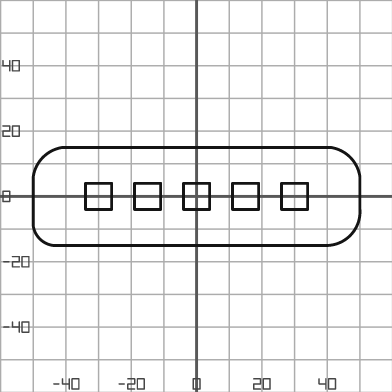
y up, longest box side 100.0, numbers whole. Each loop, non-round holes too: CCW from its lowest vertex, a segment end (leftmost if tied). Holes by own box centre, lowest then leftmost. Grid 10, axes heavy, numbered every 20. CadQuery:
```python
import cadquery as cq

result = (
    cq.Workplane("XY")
    .moveTo(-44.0, -15.0)
    .lineTo(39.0, -15.0)
    .threePointArc((47.0, -12.0), (50.0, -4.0))
    .lineTo(50.0, 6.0)
    .threePointArc((47.0, 12.0), (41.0, 15.0))
    .lineTo(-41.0, 15.0)
    .threePointArc((-47.0, 12.0), (-50.0, 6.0))
    .lineTo(-50.0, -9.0)
    .threePointArc((-48.0, -13.0), (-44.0, -15.0))
    .close()
    .moveTo(-34.0, -4.0)
    .lineTo(-26.0, -4.0)
    .lineTo(-26.0, 4.0)
    .lineTo(-34.0, 4.0)
    .close()
    .moveTo(-19.0, -4.0)
    .lineTo(-11.0, -4.0)
    .lineTo(-11.0, 4.0)
    .lineTo(-19.0, 4.0)
    .close()
    .moveTo(-4.0, -4.0)
    .lineTo(4.0, -4.0)
    .lineTo(4.0, 4.0)
    .lineTo(-4.0, 4.0)
    .close()
    .moveTo(11.0, -4.0)
    .lineTo(19.0, -4.0)
    .lineTo(19.0, 4.0)
    .lineTo(11.0, 4.0)
    .close()
    .moveTo(26.0, -4.0)
    .lineTo(34.0, -4.0)
    .lineTo(34.0, 4.0)
    .lineTo(26.0, 4.0)
    .close()
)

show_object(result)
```